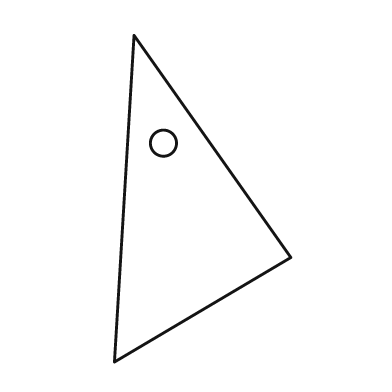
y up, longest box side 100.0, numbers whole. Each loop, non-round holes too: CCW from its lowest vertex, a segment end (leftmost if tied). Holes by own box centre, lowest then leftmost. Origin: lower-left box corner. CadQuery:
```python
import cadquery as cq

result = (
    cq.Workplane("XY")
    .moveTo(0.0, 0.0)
    .lineTo(54.0, 32.0)
    .lineTo(6.0, 100.0)
    .close()
    .moveTo(15.0, 67.0)
    .circle(4.0)
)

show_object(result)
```